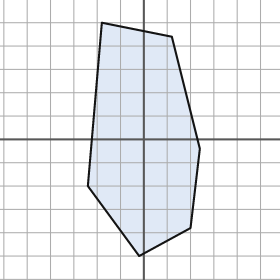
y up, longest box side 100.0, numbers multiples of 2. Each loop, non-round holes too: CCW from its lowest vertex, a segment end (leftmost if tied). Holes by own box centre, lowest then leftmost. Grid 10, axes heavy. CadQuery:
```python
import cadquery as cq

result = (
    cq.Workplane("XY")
    .moveTo(-2.0, -50.0)
    .lineTo(20.0, -38.0)
    .lineTo(24.0, -4.0)
    .lineTo(12.0, 44.0)
    .lineTo(-18.0, 50.0)
    .lineTo(-24.0, -20.0)
    .close()
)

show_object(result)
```